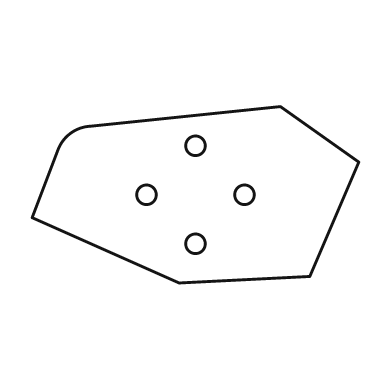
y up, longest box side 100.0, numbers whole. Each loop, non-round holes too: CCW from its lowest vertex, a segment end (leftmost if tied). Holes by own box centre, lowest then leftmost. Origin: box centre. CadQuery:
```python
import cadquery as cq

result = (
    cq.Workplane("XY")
    .moveTo(-5.0, -27.0)
    .lineTo(35.0, -25.0)
    .lineTo(50.0, 10.0)
    .lineTo(26.0, 27.0)
    .lineTo(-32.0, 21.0)
    .threePointArc((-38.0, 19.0), (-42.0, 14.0))
    .lineTo(-50.0, -7.0)
    .close()
    .moveTo(0.0, -15.0)
    .circle(3.0)
    .moveTo(-15.0, 0.0)
    .circle(3.0)
    .moveTo(15.0, 0.0)
    .circle(3.0)
    .moveTo(0.0, 15.0)
    .circle(3.0)
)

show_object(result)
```